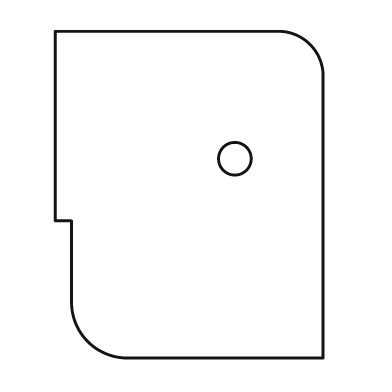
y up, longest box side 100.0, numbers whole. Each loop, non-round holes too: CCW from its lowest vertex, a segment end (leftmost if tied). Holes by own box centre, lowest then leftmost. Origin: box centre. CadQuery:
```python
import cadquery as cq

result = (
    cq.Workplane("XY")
    .moveTo(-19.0, -50.0)
    .lineTo(41.0, -50.0)
    .lineTo(41.0, 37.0)
    .threePointArc((37.0, 46.0), (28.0, 50.0))
    .lineTo(-41.0, 50.0)
    .lineTo(-41.0, -8.0)
    .lineTo(-36.0, -8.0)
    .lineTo(-36.0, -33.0)
    .threePointArc((-31.0, -45.0), (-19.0, -50.0))
    .close()
    .moveTo(14.0, 11.0)
    .circle(5.0)
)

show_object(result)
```